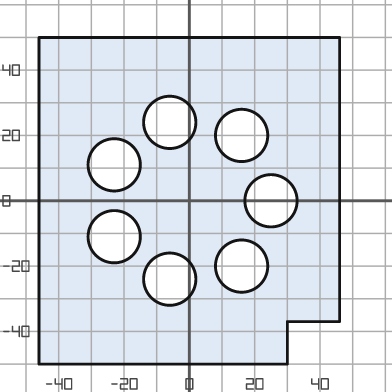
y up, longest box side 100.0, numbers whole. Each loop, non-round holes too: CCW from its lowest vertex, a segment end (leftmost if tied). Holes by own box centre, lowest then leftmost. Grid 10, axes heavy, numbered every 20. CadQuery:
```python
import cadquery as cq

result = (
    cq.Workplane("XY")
    .moveTo(-46.0, -50.0)
    .lineTo(30.0, -50.0)
    .lineTo(30.0, -37.0)
    .lineTo(46.0, -37.0)
    .lineTo(46.0, 50.0)
    .lineTo(-46.0, 50.0)
    .close()
    .moveTo(-6.0, -24.0)
    .circle(8.0)
    .moveTo(16.0, -20.0)
    .circle(8.0)
    .moveTo(-23.0, -11.0)
    .circle(8.0)
    .moveTo(25.0, 0.0)
    .circle(8.0)
    .moveTo(-23.0, 11.0)
    .circle(8.0)
    .moveTo(16.0, 20.0)
    .circle(8.0)
    .moveTo(-6.0, 24.0)
    .circle(8.0)
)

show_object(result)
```